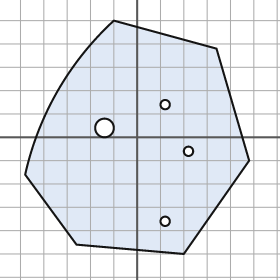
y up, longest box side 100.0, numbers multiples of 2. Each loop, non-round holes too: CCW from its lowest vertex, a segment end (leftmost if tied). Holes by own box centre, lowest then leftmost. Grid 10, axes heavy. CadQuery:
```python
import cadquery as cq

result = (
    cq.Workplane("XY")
    .moveTo(20.0, -50.0)
    .lineTo(48.0, -10.0)
    .lineTo(34.0, 38.0)
    .lineTo(-10.0, 50.0)
    .threePointArc((-34.0, 20.0), (-48.0, -16.0))
    .lineTo(-26.0, -46.0)
    .close()
    .moveTo(12.0, -36.0)
    .circle(2.0)
    .moveTo(22.0, -6.0)
    .circle(2.0)
    .moveTo(-14.0, 4.0)
    .circle(4.0)
    .moveTo(12.0, 14.0)
    .circle(2.0)
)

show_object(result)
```